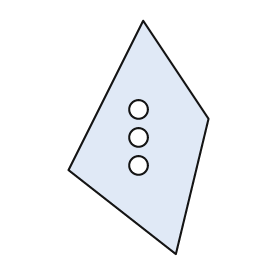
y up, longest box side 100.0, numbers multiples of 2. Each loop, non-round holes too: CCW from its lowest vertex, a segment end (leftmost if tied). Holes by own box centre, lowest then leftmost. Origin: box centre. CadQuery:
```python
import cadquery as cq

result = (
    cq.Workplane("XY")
    .moveTo(16.0, -50.0)
    .lineTo(30.0, 8.0)
    .lineTo(2.0, 50.0)
    .lineTo(-30.0, -14.0)
    .close()
    .moveTo(0.0, -12.0)
    .circle(4.0)
    .moveTo(0.0, 0.0)
    .circle(4.0)
    .moveTo(0.0, 12.0)
    .circle(4.0)
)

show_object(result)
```